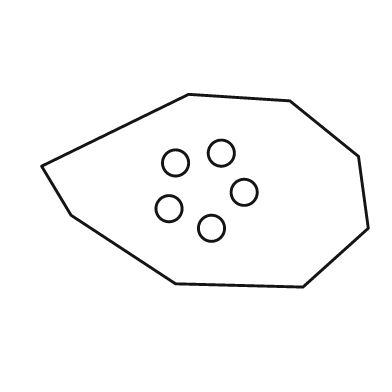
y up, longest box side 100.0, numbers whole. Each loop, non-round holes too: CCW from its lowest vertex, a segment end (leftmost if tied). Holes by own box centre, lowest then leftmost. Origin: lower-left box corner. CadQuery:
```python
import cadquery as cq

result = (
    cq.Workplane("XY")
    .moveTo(80.0, 0.0)
    .lineTo(100.0, 18.0)
    .lineTo(97.0, 40.0)
    .lineTo(76.0, 57.0)
    .lineTo(45.0, 59.0)
    .lineTo(0.0, 37.0)
    .lineTo(9.0, 22.0)
    .lineTo(41.0, 1.0)
    .close()
    .moveTo(52.0, 18.0)
    .circle(4.0)
    .moveTo(39.0, 24.0)
    .circle(4.0)
    .moveTo(62.0, 29.0)
    .circle(4.0)
    .moveTo(41.0, 38.0)
    .circle(4.0)
    .moveTo(55.0, 41.0)
    .circle(4.0)
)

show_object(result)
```